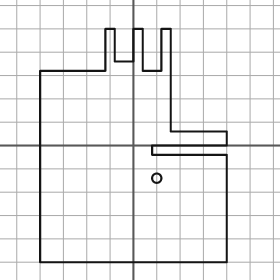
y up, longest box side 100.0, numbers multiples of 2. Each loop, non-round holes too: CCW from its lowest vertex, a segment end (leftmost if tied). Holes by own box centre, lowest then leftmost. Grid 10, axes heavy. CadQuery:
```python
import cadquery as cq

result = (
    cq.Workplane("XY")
    .moveTo(-40.0, -50.0)
    .lineTo(40.0, -50.0)
    .lineTo(40.0, -4.0)
    .lineTo(8.0, -4.0)
    .lineTo(8.0, 0.0)
    .lineTo(40.0, 0.0)
    .lineTo(40.0, 6.0)
    .lineTo(16.0, 6.0)
    .lineTo(16.0, 50.0)
    .lineTo(12.0, 50.0)
    .lineTo(12.0, 32.0)
    .lineTo(4.0, 32.0)
    .lineTo(4.0, 50.0)
    .lineTo(0.0, 50.0)
    .lineTo(0.0, 36.0)
    .lineTo(-8.0, 36.0)
    .lineTo(-8.0, 50.0)
    .lineTo(-12.0, 50.0)
    .lineTo(-12.0, 32.0)
    .lineTo(-40.0, 32.0)
    .close()
    .moveTo(10.0, -14.0)
    .circle(2.0)
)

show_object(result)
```